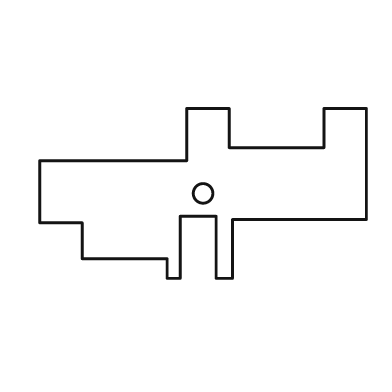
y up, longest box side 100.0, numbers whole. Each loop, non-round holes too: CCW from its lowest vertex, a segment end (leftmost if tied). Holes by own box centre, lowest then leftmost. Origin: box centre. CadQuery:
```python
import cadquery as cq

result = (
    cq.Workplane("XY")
    .moveTo(-11.0, -26.0)
    .lineTo(-7.0, -26.0)
    .lineTo(-7.0, -7.0)
    .lineTo(4.0, -7.0)
    .lineTo(4.0, -26.0)
    .lineTo(9.0, -26.0)
    .lineTo(9.0, -8.0)
    .lineTo(50.0, -8.0)
    .lineTo(50.0, 26.0)
    .lineTo(37.0, 26.0)
    .lineTo(37.0, 14.0)
    .lineTo(8.0, 14.0)
    .lineTo(8.0, 26.0)
    .lineTo(-5.0, 26.0)
    .lineTo(-5.0, 10.0)
    .lineTo(-50.0, 10.0)
    .lineTo(-50.0, -9.0)
    .lineTo(-37.0, -9.0)
    .lineTo(-37.0, -20.0)
    .lineTo(-11.0, -20.0)
    .close()
    .moveTo(0.0, 0.0)
    .circle(3.0)
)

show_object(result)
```